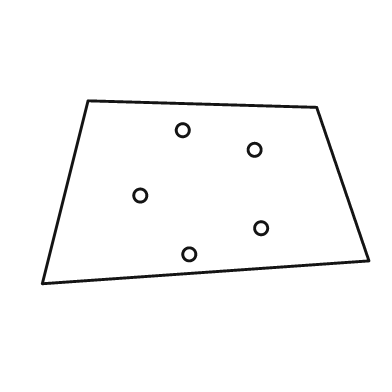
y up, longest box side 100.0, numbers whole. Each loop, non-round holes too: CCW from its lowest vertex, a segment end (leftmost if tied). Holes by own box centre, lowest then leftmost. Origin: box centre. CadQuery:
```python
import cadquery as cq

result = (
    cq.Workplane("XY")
    .moveTo(-50.0, -28.0)
    .lineTo(50.0, -21.0)
    .lineTo(34.0, 26.0)
    .lineTo(-36.0, 28.0)
    .close()
    .moveTo(-5.0, -19.0)
    .circle(2.0)
    .moveTo(17.0, -11.0)
    .circle(2.0)
    .moveTo(-20.0, -1.0)
    .circle(2.0)
    .moveTo(15.0, 13.0)
    .circle(2.0)
    .moveTo(-7.0, 19.0)
    .circle(2.0)
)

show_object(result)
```